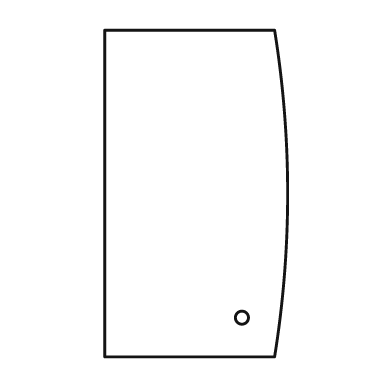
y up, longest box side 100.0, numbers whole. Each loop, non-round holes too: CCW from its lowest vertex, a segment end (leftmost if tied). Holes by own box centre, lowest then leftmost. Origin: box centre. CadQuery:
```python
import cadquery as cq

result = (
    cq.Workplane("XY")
    .moveTo(-28.0, -50.0)
    .lineTo(24.0, -50.0)
    .threePointArc((28.0, 0.0), (24.0, 50.0))
    .lineTo(-28.0, 50.0)
    .close()
    .moveTo(14.0, -38.0)
    .circle(2.0)
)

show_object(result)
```